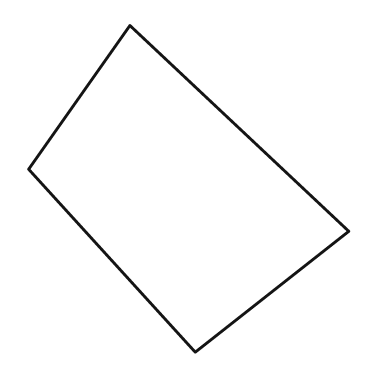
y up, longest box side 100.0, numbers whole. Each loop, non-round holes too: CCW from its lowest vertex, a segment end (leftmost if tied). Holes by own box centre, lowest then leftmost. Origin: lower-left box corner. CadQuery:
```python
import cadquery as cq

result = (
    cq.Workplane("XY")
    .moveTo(51.0, 0.0)
    .lineTo(98.0, 37.0)
    .lineTo(31.0, 100.0)
    .lineTo(0.0, 56.0)
    .close()
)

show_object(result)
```